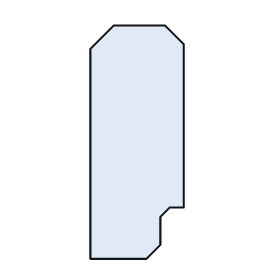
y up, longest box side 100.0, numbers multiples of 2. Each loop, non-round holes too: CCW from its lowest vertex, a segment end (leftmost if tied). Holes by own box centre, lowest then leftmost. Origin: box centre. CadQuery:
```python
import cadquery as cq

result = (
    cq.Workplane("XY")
    .moveTo(-20.0, -50.0)
    .lineTo(4.0, -50.0)
    .lineTo(10.0, -44.0)
    .lineTo(10.0, -32.0)
    .lineTo(14.0, -28.0)
    .lineTo(20.0, -28.0)
    .lineTo(20.0, 42.0)
    .lineTo(12.0, 50.0)
    .lineTo(-10.0, 50.0)
    .lineTo(-20.0, 40.0)
    .close()
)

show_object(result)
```